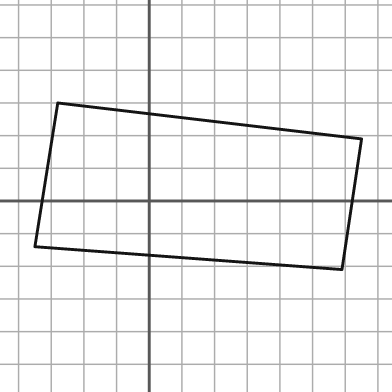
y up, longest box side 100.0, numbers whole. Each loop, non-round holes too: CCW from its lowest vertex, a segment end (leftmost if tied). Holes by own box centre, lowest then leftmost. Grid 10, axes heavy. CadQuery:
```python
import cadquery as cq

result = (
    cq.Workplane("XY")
    .moveTo(59.0, -21.0)
    .lineTo(65.0, 19.0)
    .lineTo(-28.0, 30.0)
    .lineTo(-35.0, -14.0)
    .close()
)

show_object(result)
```